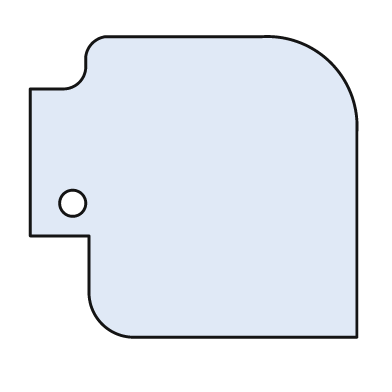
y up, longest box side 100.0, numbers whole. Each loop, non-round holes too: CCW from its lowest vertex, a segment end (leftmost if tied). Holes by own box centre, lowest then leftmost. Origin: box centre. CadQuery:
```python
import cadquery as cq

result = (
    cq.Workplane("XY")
    .moveTo(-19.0, -46.0)
    .lineTo(50.0, -46.0)
    .lineTo(50.0, 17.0)
    .threePointArc((42.0, 38.0), (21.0, 46.0))
    .lineTo(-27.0, 46.0)
    .threePointArc((-31.0, 44.0), (-33.0, 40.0))
    .lineTo(-33.0, 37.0)
    .threePointArc((-35.0, 32.0), (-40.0, 30.0))
    .lineTo(-50.0, 30.0)
    .lineTo(-50.0, -15.0)
    .lineTo(-32.0, -15.0)
    .lineTo(-32.0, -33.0)
    .threePointArc((-28.0, -42.0), (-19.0, -46.0))
    .close()
    .moveTo(-37.0, -5.0)
    .circle(4.0)
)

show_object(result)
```